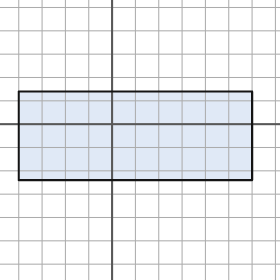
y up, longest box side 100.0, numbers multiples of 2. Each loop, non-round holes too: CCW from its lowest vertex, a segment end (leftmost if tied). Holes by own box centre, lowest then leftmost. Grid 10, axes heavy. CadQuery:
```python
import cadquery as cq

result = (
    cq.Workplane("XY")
    .moveTo(-40.0, -24.0)
    .lineTo(60.0, -24.0)
    .lineTo(60.0, 14.0)
    .lineTo(-40.0, 14.0)
    .close()
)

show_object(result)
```